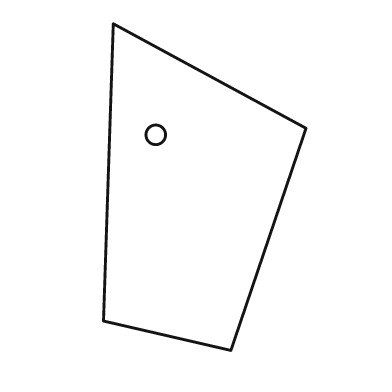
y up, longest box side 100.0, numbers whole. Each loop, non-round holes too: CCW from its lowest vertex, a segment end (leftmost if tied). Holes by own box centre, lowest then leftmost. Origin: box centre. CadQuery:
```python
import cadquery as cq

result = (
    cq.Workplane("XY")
    .moveTo(8.0, -50.0)
    .lineTo(31.0, 18.0)
    .lineTo(-28.0, 50.0)
    .lineTo(-31.0, -41.0)
    .close()
    .moveTo(-15.0, 16.0)
    .circle(3.0)
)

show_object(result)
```